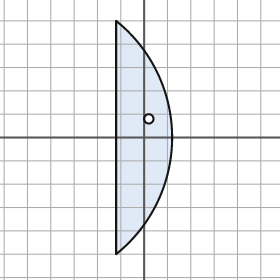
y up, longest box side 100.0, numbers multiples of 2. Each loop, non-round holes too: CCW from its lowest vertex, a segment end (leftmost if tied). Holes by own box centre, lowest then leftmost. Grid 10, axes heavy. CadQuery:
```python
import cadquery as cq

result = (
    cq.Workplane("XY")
    .moveTo(-12.0, -50.0)
    .threePointArc((12.0, 0.0), (-12.0, 50.0))
    .close()
    .moveTo(2.0, 8.0)
    .circle(2.0)
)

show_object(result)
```